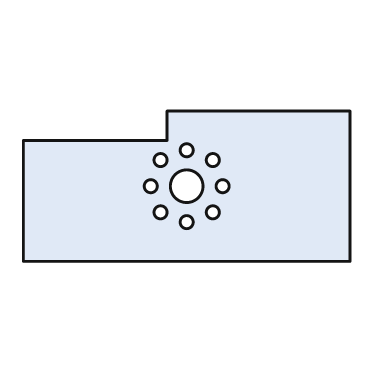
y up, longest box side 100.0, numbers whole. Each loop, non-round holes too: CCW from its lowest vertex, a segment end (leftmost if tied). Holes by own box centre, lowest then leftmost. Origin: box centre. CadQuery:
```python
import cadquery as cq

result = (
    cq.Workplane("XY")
    .moveTo(-50.0, -23.0)
    .lineTo(50.0, -23.0)
    .lineTo(50.0, 23.0)
    .lineTo(-6.0, 23.0)
    .lineTo(-6.0, 14.0)
    .lineTo(-50.0, 14.0)
    .close()
    .moveTo(0.0, -11.0)
    .circle(2.0)
    .moveTo(-8.0, -8.0)
    .circle(2.0)
    .moveTo(8.0, -8.0)
    .circle(2.0)
    .moveTo(-11.0, 0.0)
    .circle(2.0)
    .moveTo(0.0, 0.0)
    .circle(5.0)
    .moveTo(11.0, 0.0)
    .circle(2.0)
    .moveTo(-8.0, 8.0)
    .circle(2.0)
    .moveTo(8.0, 8.0)
    .circle(2.0)
    .moveTo(0.0, 11.0)
    .circle(2.0)
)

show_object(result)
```